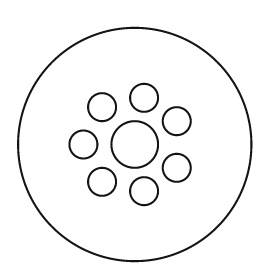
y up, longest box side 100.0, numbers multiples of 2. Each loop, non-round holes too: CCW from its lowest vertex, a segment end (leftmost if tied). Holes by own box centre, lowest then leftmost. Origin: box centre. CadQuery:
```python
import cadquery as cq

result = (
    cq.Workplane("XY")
    .moveTo(0.0, 0.0)
    .circle(50.0)
    .moveTo(4.0, -20.0)
    .circle(6.0)
    .moveTo(-14.0, -16.0)
    .circle(6.0)
    .moveTo(18.0, -10.0)
    .circle(6.0)
    .moveTo(-22.0, 0.0)
    .circle(6.0)
    .moveTo(0.0, 0.0)
    .circle(10.0)
    .moveTo(18.0, 10.0)
    .circle(6.0)
    .moveTo(-14.0, 16.0)
    .circle(6.0)
    .moveTo(4.0, 20.0)
    .circle(6.0)
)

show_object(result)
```